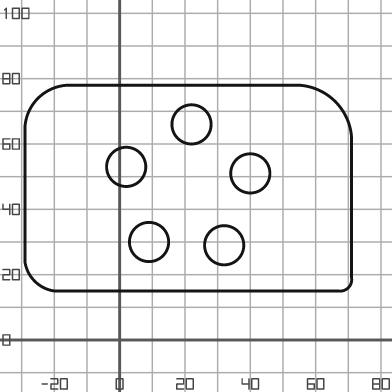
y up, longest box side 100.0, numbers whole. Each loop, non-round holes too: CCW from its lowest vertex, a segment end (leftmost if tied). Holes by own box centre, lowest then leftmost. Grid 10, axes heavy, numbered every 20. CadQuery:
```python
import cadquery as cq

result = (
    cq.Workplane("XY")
    .moveTo(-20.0, 15.0)
    .lineTo(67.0, 15.0)
    .threePointArc((70.0, 16.0), (71.0, 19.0))
    .lineTo(71.0, 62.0)
    .threePointArc((66.0, 73.0), (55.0, 78.0))
    .lineTo(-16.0, 78.0)
    .threePointArc((-25.0, 74.0), (-29.0, 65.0))
    .lineTo(-29.0, 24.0)
    .threePointArc((-26.0, 18.0), (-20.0, 15.0))
    .close()
    .moveTo(32.0, 29.0)
    .circle(6.0)
    .moveTo(9.0, 30.0)
    .circle(6.0)
    .moveTo(40.0, 51.0)
    .circle(6.0)
    .moveTo(2.0, 53.0)
    .circle(6.0)
    .moveTo(22.0, 66.0)
    .circle(6.0)
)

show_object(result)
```